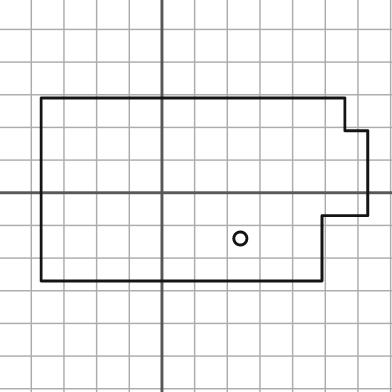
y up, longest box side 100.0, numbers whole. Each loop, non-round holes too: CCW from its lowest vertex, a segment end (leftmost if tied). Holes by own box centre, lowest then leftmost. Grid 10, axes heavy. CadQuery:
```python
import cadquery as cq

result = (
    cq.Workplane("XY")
    .moveTo(-37.0, -27.0)
    .lineTo(49.0, -27.0)
    .lineTo(49.0, -7.0)
    .lineTo(63.0, -7.0)
    .lineTo(63.0, 19.0)
    .lineTo(56.0, 19.0)
    .lineTo(56.0, 29.0)
    .lineTo(-37.0, 29.0)
    .close()
    .moveTo(24.0, -14.0)
    .circle(2.0)
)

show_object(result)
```